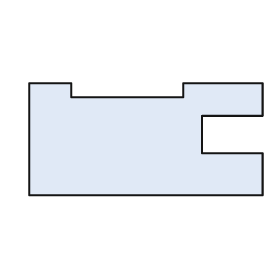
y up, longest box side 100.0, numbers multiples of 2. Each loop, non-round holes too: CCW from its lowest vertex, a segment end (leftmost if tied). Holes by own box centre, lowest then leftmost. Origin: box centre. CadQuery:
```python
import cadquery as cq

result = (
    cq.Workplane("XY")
    .moveTo(-50.0, -24.0)
    .lineTo(50.0, -24.0)
    .lineTo(50.0, -6.0)
    .lineTo(24.0, -6.0)
    .lineTo(24.0, 10.0)
    .lineTo(50.0, 10.0)
    .lineTo(50.0, 24.0)
    .lineTo(16.0, 24.0)
    .lineTo(16.0, 18.0)
    .lineTo(-32.0, 18.0)
    .lineTo(-32.0, 24.0)
    .lineTo(-50.0, 24.0)
    .close()
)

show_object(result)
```